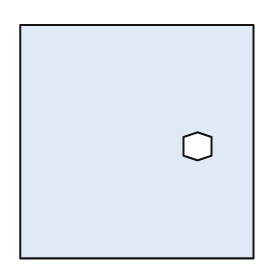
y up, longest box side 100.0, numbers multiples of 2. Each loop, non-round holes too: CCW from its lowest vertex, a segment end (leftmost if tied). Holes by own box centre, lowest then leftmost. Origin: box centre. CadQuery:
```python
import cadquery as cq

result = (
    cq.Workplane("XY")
    .moveTo(-50.0, -50.0)
    .lineTo(50.0, -50.0)
    .lineTo(50.0, 50.0)
    .lineTo(-50.0, 50.0)
    .close()
    .moveTo(26.0, -8.0)
    .lineTo(32.0, -6.0)
    .lineTo(32.0, 2.0)
    .lineTo(26.0, 4.0)
    .lineTo(20.0, 2.0)
    .lineTo(20.0, -6.0)
    .close()
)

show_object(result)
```